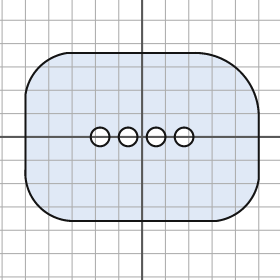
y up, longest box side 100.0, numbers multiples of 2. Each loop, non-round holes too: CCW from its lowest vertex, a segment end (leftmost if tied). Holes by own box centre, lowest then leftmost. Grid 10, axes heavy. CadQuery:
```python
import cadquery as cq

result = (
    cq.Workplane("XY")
    .moveTo(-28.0, -36.0)
    .lineTo(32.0, -36.0)
    .threePointArc((44.0, -30.0), (50.0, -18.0))
    .lineTo(50.0, 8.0)
    .threePointArc((42.0, 28.0), (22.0, 36.0))
    .lineTo(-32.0, 36.0)
    .threePointArc((-44.0, 30.0), (-50.0, 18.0))
    .lineTo(-50.0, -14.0)
    .threePointArc((-44.0, -30.0), (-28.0, -36.0))
    .close()
    .moveTo(-18.0, 0.0)
    .circle(4.0)
    .moveTo(-6.0, 0.0)
    .circle(4.0)
    .moveTo(6.0, 0.0)
    .circle(4.0)
    .moveTo(18.0, 0.0)
    .circle(4.0)
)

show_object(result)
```